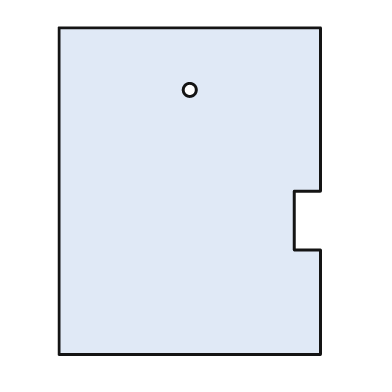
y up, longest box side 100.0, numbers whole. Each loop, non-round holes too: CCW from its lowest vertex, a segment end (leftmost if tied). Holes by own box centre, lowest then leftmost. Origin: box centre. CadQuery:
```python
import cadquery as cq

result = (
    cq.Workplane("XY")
    .moveTo(-40.0, -50.0)
    .lineTo(40.0, -50.0)
    .lineTo(40.0, -18.0)
    .lineTo(32.0, -18.0)
    .lineTo(32.0, 0.0)
    .lineTo(40.0, 0.0)
    .lineTo(40.0, 50.0)
    .lineTo(-40.0, 50.0)
    .close()
    .moveTo(0.0, 31.0)
    .circle(2.0)
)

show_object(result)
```